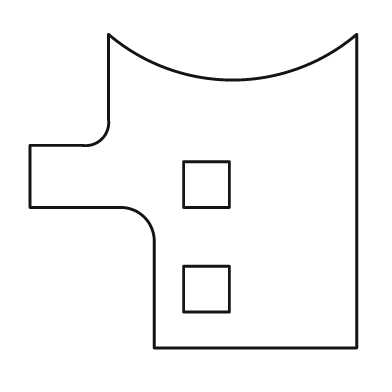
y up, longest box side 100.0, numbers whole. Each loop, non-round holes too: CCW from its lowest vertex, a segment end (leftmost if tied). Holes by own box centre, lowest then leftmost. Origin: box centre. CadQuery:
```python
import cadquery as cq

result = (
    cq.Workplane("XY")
    .moveTo(-12.0, -48.0)
    .lineTo(50.0, -48.0)
    .lineTo(50.0, 48.0)
    .threePointArc((12.0, 34.0), (-26.0, 48.0))
    .lineTo(-26.0, 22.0)
    .threePointArc((-28.0, 16.0), (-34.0, 14.0))
    .lineTo(-50.0, 14.0)
    .lineTo(-50.0, -5.0)
    .lineTo(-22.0, -5.0)
    .threePointArc((-15.0, -8.0), (-12.0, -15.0))
    .close()
    .moveTo(-3.0, -37.0)
    .lineTo(11.0, -37.0)
    .lineTo(11.0, -23.0)
    .lineTo(-3.0, -23.0)
    .close()
    .moveTo(-3.0, -5.0)
    .lineTo(11.0, -5.0)
    .lineTo(11.0, 9.0)
    .lineTo(-3.0, 9.0)
    .close()
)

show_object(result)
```